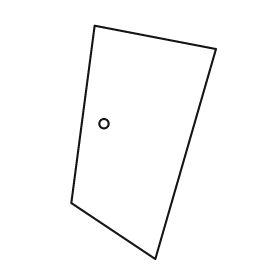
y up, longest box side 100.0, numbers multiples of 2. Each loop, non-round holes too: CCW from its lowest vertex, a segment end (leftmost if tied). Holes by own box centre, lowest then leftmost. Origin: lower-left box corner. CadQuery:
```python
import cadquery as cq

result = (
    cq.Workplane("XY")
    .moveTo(36.0, 0.0)
    .lineTo(62.0, 90.0)
    .lineTo(10.0, 100.0)
    .lineTo(0.0, 24.0)
    .close()
    .moveTo(14.0, 58.0)
    .circle(2.0)
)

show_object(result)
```